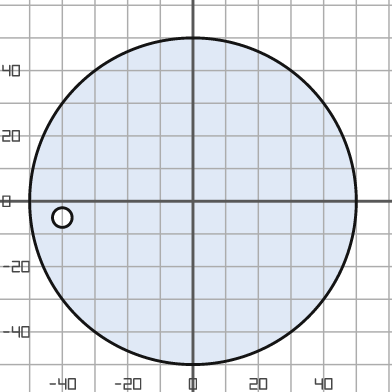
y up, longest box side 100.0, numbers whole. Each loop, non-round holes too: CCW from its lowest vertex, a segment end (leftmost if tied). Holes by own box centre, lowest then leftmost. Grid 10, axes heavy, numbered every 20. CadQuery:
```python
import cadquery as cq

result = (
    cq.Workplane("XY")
    .moveTo(0.0, 0.0)
    .circle(50.0)
    .moveTo(-40.0, -5.0)
    .circle(3.0)
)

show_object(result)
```